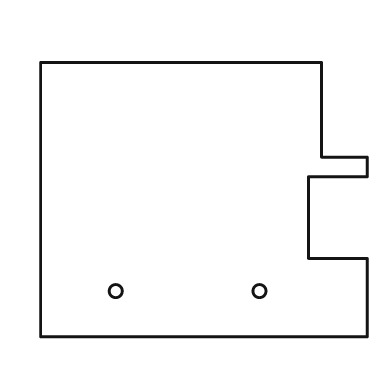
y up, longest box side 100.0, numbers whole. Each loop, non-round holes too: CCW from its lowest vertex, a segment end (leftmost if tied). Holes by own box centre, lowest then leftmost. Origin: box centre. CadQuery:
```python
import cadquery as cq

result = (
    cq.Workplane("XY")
    .moveTo(-50.0, -42.0)
    .lineTo(50.0, -42.0)
    .lineTo(50.0, -18.0)
    .lineTo(32.0, -18.0)
    .lineTo(32.0, 7.0)
    .lineTo(50.0, 7.0)
    .lineTo(50.0, 13.0)
    .lineTo(36.0, 13.0)
    .lineTo(36.0, 42.0)
    .lineTo(-50.0, 42.0)
    .close()
    .moveTo(-27.0, -28.0)
    .circle(2.0)
    .moveTo(17.0, -28.0)
    .circle(2.0)
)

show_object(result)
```